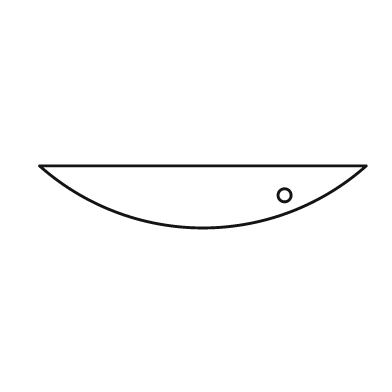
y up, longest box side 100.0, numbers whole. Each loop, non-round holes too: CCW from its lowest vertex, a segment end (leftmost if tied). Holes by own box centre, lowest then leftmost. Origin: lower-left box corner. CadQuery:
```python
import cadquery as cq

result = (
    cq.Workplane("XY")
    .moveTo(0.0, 19.0)
    .threePointArc((50.0, 0.0), (100.0, 19.0))
    .close()
    .moveTo(75.0, 10.0)
    .circle(2.0)
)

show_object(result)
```